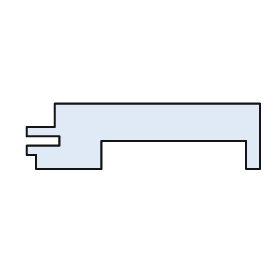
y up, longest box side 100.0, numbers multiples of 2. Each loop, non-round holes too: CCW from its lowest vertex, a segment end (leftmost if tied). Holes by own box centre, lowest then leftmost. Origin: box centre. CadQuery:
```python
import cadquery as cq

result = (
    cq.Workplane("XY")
    .moveTo(-46.0, -14.0)
    .lineTo(-18.0, -14.0)
    .lineTo(-18.0, -2.0)
    .lineTo(44.0, -2.0)
    .lineTo(44.0, -14.0)
    .lineTo(50.0, -14.0)
    .lineTo(50.0, 14.0)
    .lineTo(-38.0, 14.0)
    .lineTo(-38.0, 4.0)
    .lineTo(-50.0, 4.0)
    .lineTo(-50.0, 0.0)
    .lineTo(-36.0, 0.0)
    .lineTo(-36.0, -4.0)
    .lineTo(-50.0, -4.0)
    .lineTo(-50.0, -8.0)
    .lineTo(-46.0, -8.0)
    .close()
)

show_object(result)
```